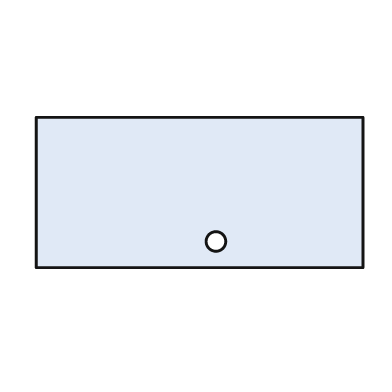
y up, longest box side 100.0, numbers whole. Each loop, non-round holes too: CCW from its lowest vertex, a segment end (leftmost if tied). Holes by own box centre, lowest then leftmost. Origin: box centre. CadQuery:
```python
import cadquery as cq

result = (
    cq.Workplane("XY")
    .moveTo(-50.0, -23.0)
    .lineTo(50.0, -23.0)
    .lineTo(50.0, 23.0)
    .lineTo(-50.0, 23.0)
    .close()
    .moveTo(5.0, -15.0)
    .circle(3.0)
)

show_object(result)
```